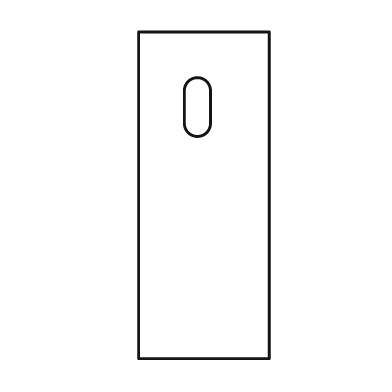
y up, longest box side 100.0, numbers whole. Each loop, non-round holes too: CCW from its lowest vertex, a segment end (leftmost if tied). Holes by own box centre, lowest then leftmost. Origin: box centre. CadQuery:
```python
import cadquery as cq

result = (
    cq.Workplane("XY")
    .moveTo(-20.0, -50.0)
    .lineTo(20.0, -50.0)
    .lineTo(20.0, 50.0)
    .lineTo(-20.0, 50.0)
    .close()
    .moveTo(-6.0, 22.0)
    .threePointArc((-2.0, 18.0), (2.0, 22.0))
    .lineTo(2.0, 32.0)
    .threePointArc((-2.0, 36.0), (-6.0, 32.0))
    .close()
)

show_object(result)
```